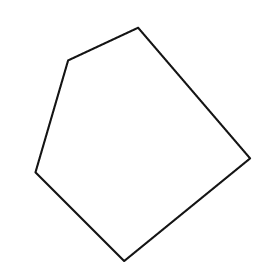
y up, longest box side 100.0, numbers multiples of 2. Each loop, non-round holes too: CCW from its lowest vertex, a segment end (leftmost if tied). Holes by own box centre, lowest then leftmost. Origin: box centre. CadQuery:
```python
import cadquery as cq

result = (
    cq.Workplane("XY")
    .moveTo(-8.0, -50.0)
    .lineTo(46.0, -6.0)
    .lineTo(-2.0, 50.0)
    .lineTo(-32.0, 36.0)
    .lineTo(-46.0, -12.0)
    .close()
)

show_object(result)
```